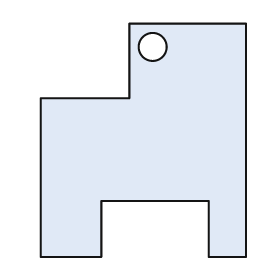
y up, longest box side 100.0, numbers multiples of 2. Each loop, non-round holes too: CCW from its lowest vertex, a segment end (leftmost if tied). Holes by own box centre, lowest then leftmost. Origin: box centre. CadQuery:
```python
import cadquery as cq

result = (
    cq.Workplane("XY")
    .moveTo(-44.0, -50.0)
    .lineTo(-18.0, -50.0)
    .lineTo(-18.0, -26.0)
    .lineTo(28.0, -26.0)
    .lineTo(28.0, -50.0)
    .lineTo(44.0, -50.0)
    .lineTo(44.0, 50.0)
    .lineTo(-6.0, 50.0)
    .lineTo(-6.0, 18.0)
    .lineTo(-44.0, 18.0)
    .close()
    .moveTo(4.0, 40.0)
    .circle(6.0)
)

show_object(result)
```